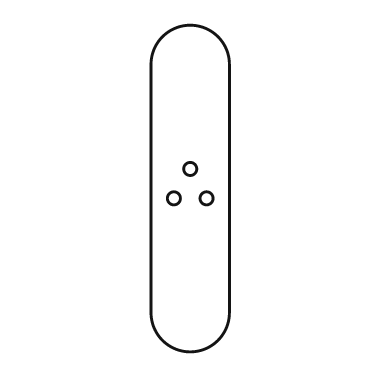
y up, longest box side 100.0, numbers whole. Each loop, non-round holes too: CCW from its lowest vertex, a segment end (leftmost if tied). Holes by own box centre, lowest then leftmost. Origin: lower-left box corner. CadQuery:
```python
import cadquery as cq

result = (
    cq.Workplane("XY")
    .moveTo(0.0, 12.0)
    .threePointArc((12.0, 0.0), (24.0, 12.0))
    .lineTo(24.0, 88.0)
    .threePointArc((12.0, 100.0), (0.0, 88.0))
    .close()
    .moveTo(7.0, 47.0)
    .circle(2.0)
    .moveTo(17.0, 47.0)
    .circle(2.0)
    .moveTo(12.0, 56.0)
    .circle(2.0)
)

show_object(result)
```